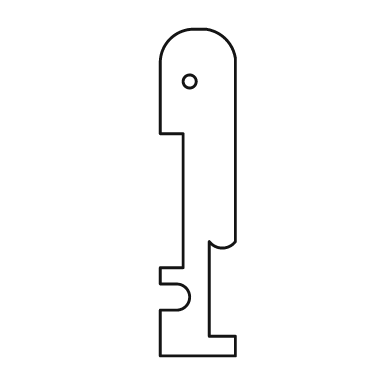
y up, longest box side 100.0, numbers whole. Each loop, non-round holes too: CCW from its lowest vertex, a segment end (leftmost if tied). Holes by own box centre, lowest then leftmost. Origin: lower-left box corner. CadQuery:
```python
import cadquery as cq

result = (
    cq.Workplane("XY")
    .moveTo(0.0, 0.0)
    .lineTo(23.0, 0.0)
    .lineTo(23.0, 6.0)
    .lineTo(15.0, 6.0)
    .lineTo(15.0, 35.0)
    .threePointArc((19.0, 33.0), (23.0, 35.0))
    .lineTo(23.0, 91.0)
    .threePointArc((20.0, 97.0), (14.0, 100.0))
    .lineTo(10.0, 100.0)
    .threePointArc((3.0, 97.0), (0.0, 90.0))
    .lineTo(0.0, 68.0)
    .lineTo(7.0, 68.0)
    .lineTo(7.0, 27.0)
    .lineTo(0.0, 27.0)
    .lineTo(0.0, 22.0)
    .lineTo(5.0, 22.0)
    .threePointArc((9.0, 18.0), (5.0, 14.0))
    .lineTo(0.0, 14.0)
    .close()
    .moveTo(9.0, 84.0)
    .circle(2.0)
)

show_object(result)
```